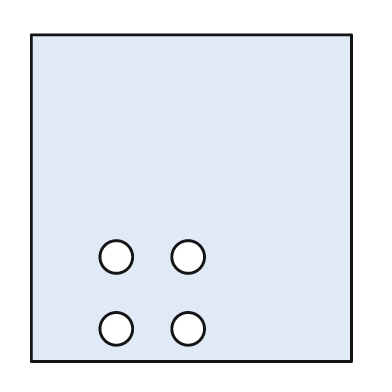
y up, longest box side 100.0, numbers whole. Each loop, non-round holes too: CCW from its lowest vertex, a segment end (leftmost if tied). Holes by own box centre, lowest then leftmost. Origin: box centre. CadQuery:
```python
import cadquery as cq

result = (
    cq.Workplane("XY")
    .moveTo(-49.0, -50.0)
    .lineTo(49.0, -50.0)
    .lineTo(49.0, 50.0)
    .lineTo(-49.0, 50.0)
    .close()
    .moveTo(-23.0, -40.0)
    .circle(5.0)
    .moveTo(-1.0, -40.0)
    .circle(5.0)
    .moveTo(-23.0, -18.0)
    .circle(5.0)
    .moveTo(-1.0, -18.0)
    .circle(5.0)
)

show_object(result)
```